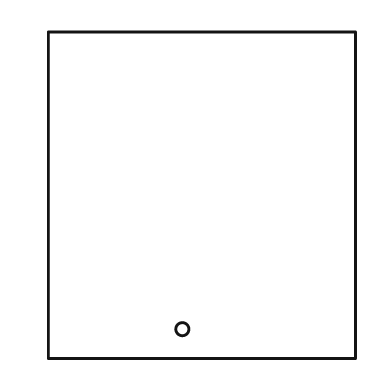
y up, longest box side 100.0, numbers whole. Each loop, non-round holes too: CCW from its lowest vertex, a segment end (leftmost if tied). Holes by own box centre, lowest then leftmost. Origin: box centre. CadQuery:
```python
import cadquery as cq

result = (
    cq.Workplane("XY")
    .moveTo(-47.0, -50.0)
    .lineTo(47.0, -50.0)
    .lineTo(47.0, 50.0)
    .lineTo(-47.0, 50.0)
    .close()
    .moveTo(-6.0, -41.0)
    .circle(2.0)
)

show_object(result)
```